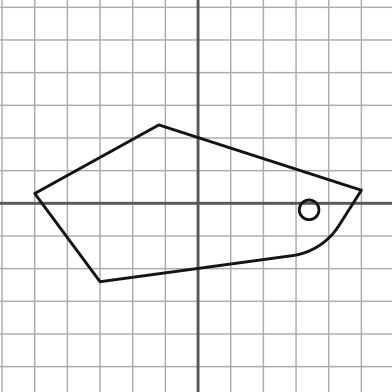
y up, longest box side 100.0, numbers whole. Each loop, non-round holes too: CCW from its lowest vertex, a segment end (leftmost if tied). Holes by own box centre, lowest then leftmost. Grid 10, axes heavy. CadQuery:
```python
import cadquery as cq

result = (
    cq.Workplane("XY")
    .moveTo(-30.0, -24.0)
    .lineTo(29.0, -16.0)
    .threePointArc((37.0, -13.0), (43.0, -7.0))
    .lineTo(50.0, 4.0)
    .lineTo(-12.0, 24.0)
    .lineTo(-50.0, 3.0)
    .close()
    .moveTo(34.0, -2.0)
    .circle(3.0)
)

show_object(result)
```